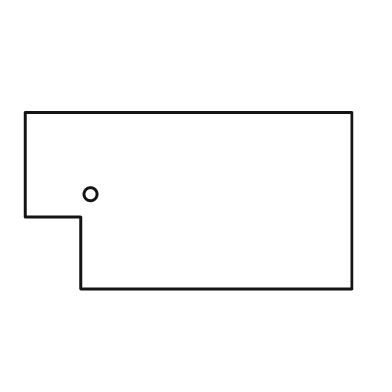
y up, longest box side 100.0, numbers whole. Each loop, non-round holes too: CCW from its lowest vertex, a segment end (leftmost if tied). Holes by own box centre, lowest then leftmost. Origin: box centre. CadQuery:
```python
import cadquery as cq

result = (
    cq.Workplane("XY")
    .moveTo(-33.0, -27.0)
    .lineTo(50.0, -27.0)
    .lineTo(50.0, 27.0)
    .lineTo(-50.0, 27.0)
    .lineTo(-50.0, -5.0)
    .lineTo(-33.0, -5.0)
    .close()
    .moveTo(-30.0, 2.0)
    .circle(2.0)
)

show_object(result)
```